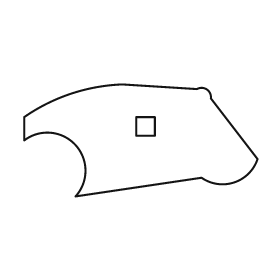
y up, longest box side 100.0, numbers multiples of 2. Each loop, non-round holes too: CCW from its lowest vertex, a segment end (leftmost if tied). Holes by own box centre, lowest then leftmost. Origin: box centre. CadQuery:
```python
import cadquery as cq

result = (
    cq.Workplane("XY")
    .moveTo(-28.0, -24.0)
    .lineTo(26.0, -16.0)
    .threePointArc((40.0, -18.0), (50.0, -8.0))
    .lineTo(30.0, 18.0)
    .threePointArc((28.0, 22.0), (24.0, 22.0))
    .lineTo(-8.0, 24.0)
    .threePointArc((-30.0, 20.0), (-50.0, 10.0))
    .lineTo(-50.0, 0.0)
    .threePointArc((-28.0, -2.0), (-28.0, -24.0))
    .close()
    .moveTo(-2.0, 2.0)
    .lineTo(6.0, 2.0)
    .lineTo(6.0, 10.0)
    .lineTo(-2.0, 10.0)
    .close()
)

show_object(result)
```